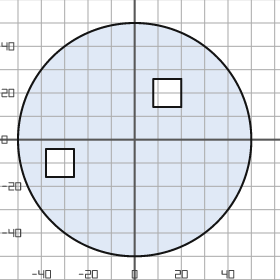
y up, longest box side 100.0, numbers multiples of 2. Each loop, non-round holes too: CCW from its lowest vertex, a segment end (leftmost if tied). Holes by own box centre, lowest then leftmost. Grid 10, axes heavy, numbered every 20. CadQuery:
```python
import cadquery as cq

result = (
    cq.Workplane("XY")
    .moveTo(0.0, 0.0)
    .circle(50.0)
    .moveTo(-38.0, -16.0)
    .lineTo(-26.0, -16.0)
    .lineTo(-26.0, -4.0)
    .lineTo(-38.0, -4.0)
    .close()
    .moveTo(8.0, 14.0)
    .lineTo(20.0, 14.0)
    .lineTo(20.0, 26.0)
    .lineTo(8.0, 26.0)
    .close()
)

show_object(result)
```